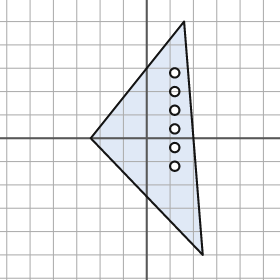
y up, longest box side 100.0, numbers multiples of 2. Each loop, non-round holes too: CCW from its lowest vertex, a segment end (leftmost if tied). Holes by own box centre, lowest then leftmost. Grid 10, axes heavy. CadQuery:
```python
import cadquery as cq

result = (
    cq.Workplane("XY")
    .moveTo(24.0, -50.0)
    .lineTo(16.0, 50.0)
    .lineTo(-24.0, 0.0)
    .close()
    .moveTo(12.0, -12.0)
    .circle(2.0)
    .moveTo(12.0, -4.0)
    .circle(2.0)
    .moveTo(12.0, 4.0)
    .circle(2.0)
    .moveTo(12.0, 12.0)
    .circle(2.0)
    .moveTo(12.0, 20.0)
    .circle(2.0)
    .moveTo(12.0, 28.0)
    .circle(2.0)
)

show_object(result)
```